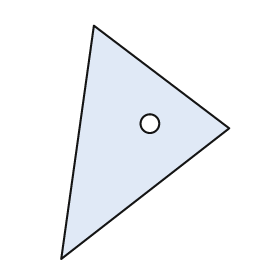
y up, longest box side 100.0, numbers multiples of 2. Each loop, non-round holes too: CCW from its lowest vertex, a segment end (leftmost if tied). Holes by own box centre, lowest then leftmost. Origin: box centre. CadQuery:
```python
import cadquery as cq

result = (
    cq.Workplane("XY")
    .moveTo(-36.0, -50.0)
    .lineTo(36.0, 6.0)
    .lineTo(-22.0, 50.0)
    .close()
    .moveTo(2.0, 8.0)
    .circle(4.0)
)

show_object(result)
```